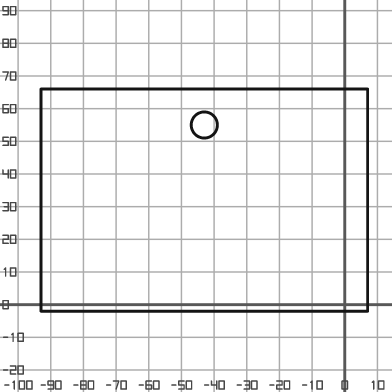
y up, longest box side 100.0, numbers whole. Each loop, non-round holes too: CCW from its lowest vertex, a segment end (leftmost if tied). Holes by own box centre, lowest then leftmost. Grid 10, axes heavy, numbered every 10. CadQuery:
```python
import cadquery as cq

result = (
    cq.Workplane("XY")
    .moveTo(-93.0, -2.0)
    .lineTo(7.0, -2.0)
    .lineTo(7.0, 66.0)
    .lineTo(-93.0, 66.0)
    .close()
    .moveTo(-43.0, 55.0)
    .circle(4.0)
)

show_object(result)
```